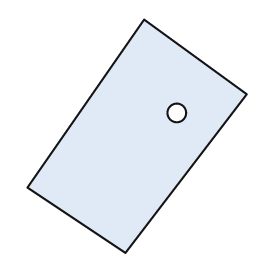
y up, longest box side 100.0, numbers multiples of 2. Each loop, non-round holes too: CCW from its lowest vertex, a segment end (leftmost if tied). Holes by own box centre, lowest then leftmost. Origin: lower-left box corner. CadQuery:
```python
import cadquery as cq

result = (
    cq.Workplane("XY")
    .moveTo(42.0, 0.0)
    .lineTo(94.0, 68.0)
    .lineTo(50.0, 100.0)
    .lineTo(0.0, 28.0)
    .close()
    .moveTo(64.0, 60.0)
    .circle(4.0)
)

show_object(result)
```